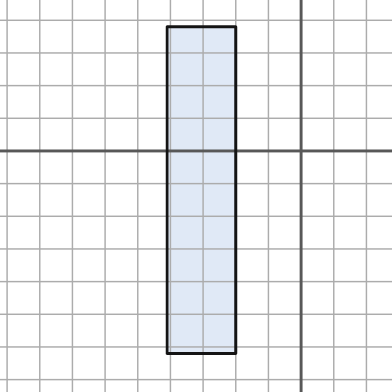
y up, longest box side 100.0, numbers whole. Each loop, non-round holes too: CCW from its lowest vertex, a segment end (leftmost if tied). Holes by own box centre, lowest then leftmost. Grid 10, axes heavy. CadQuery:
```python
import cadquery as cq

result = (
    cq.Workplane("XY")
    .moveTo(-41.0, -62.0)
    .lineTo(-20.0, -62.0)
    .lineTo(-20.0, 38.0)
    .lineTo(-41.0, 38.0)
    .close()
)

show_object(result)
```